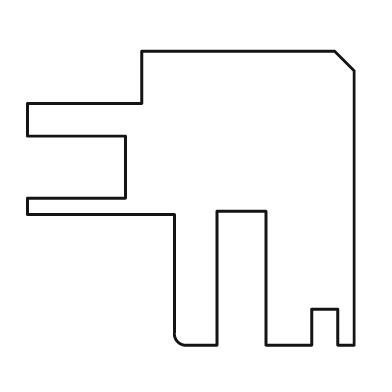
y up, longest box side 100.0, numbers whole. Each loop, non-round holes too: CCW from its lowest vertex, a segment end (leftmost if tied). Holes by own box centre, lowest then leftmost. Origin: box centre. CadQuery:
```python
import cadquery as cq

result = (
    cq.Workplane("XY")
    .moveTo(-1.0, -45.0)
    .lineTo(8.0, -45.0)
    .lineTo(8.0, -4.0)
    .lineTo(23.0, -4.0)
    .lineTo(23.0, -45.0)
    .lineTo(37.0, -45.0)
    .lineTo(37.0, -34.0)
    .lineTo(45.0, -34.0)
    .lineTo(45.0, -45.0)
    .lineTo(50.0, -45.0)
    .lineTo(50.0, 39.0)
    .lineTo(44.0, 45.0)
    .lineTo(-15.0, 45.0)
    .lineTo(-15.0, 29.0)
    .lineTo(-50.0, 29.0)
    .lineTo(-50.0, 19.0)
    .lineTo(-20.0, 19.0)
    .lineTo(-20.0, 0.0)
    .lineTo(-50.0, 0.0)
    .lineTo(-50.0, -5.0)
    .lineTo(-5.0, -5.0)
    .lineTo(-5.0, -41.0)
    .threePointArc((-4.0, -44.0), (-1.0, -45.0))
    .close()
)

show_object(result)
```